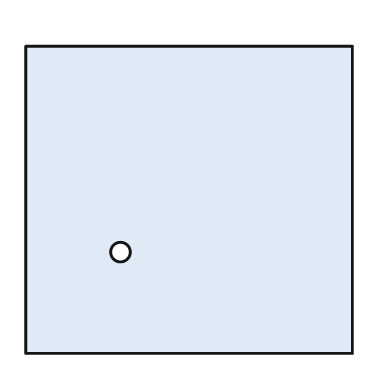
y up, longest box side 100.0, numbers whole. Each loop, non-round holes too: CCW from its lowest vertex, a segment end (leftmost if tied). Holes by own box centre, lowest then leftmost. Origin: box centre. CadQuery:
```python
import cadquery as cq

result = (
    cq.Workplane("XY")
    .moveTo(-50.0, -47.0)
    .lineTo(50.0, -47.0)
    .lineTo(50.0, 47.0)
    .lineTo(-50.0, 47.0)
    .close()
    .moveTo(-21.0, -16.0)
    .circle(3.0)
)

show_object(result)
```